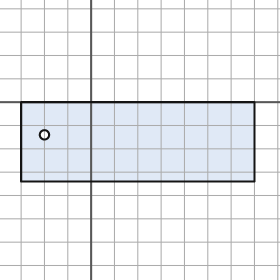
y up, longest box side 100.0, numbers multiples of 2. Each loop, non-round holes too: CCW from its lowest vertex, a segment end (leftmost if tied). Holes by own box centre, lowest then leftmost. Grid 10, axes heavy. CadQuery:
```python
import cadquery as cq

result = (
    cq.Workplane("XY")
    .moveTo(-30.0, -34.0)
    .lineTo(70.0, -34.0)
    .lineTo(70.0, 0.0)
    .lineTo(-30.0, 0.0)
    .close()
    .moveTo(-20.0, -14.0)
    .circle(2.0)
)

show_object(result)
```